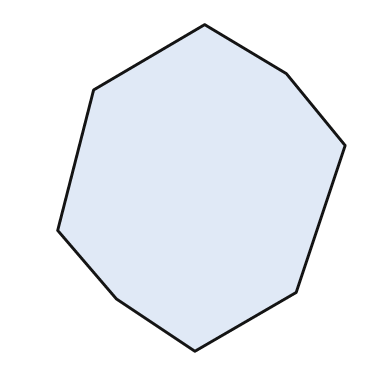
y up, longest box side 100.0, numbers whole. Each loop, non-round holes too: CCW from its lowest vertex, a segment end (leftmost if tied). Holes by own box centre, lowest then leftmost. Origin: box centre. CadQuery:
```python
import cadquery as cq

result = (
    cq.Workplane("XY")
    .moveTo(-2.0, -50.0)
    .lineTo(29.0, -32.0)
    .lineTo(44.0, 13.0)
    .lineTo(26.0, 35.0)
    .lineTo(1.0, 50.0)
    .lineTo(-33.0, 30.0)
    .lineTo(-44.0, -13.0)
    .lineTo(-26.0, -34.0)
    .close()
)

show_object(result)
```